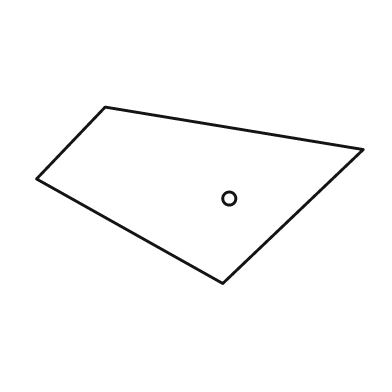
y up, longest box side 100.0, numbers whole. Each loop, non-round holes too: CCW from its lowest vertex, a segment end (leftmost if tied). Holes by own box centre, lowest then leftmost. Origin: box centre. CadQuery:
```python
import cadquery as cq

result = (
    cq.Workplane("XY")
    .moveTo(7.0, -27.0)
    .lineTo(50.0, 14.0)
    .lineTo(-29.0, 27.0)
    .lineTo(-50.0, 5.0)
    .close()
    .moveTo(9.0, -1.0)
    .circle(2.0)
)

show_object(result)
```